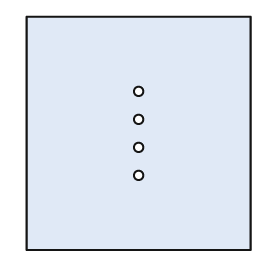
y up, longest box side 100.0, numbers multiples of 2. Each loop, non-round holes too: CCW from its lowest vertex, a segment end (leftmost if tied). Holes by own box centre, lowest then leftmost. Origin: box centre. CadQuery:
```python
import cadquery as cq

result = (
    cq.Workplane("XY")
    .moveTo(-48.0, -50.0)
    .lineTo(48.0, -50.0)
    .lineTo(48.0, 50.0)
    .lineTo(-48.0, 50.0)
    .close()
    .moveTo(0.0, -18.0)
    .circle(2.0)
    .moveTo(0.0, -6.0)
    .circle(2.0)
    .moveTo(0.0, 6.0)
    .circle(2.0)
    .moveTo(0.0, 18.0)
    .circle(2.0)
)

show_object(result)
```